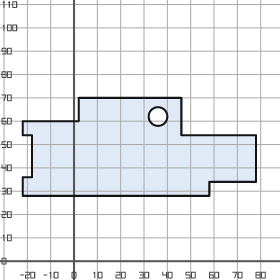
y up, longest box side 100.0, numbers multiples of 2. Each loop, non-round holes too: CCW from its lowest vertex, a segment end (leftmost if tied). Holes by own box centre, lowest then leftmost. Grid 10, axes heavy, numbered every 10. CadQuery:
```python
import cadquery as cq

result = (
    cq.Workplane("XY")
    .moveTo(-22.0, 28.0)
    .lineTo(58.0, 28.0)
    .lineTo(58.0, 34.0)
    .lineTo(78.0, 34.0)
    .lineTo(78.0, 54.0)
    .lineTo(46.0, 54.0)
    .lineTo(46.0, 70.0)
    .lineTo(2.0, 70.0)
    .lineTo(2.0, 60.0)
    .lineTo(-22.0, 60.0)
    .lineTo(-22.0, 54.0)
    .lineTo(-18.0, 54.0)
    .lineTo(-18.0, 36.0)
    .lineTo(-22.0, 36.0)
    .close()
    .moveTo(36.0, 62.0)
    .circle(4.0)
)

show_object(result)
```